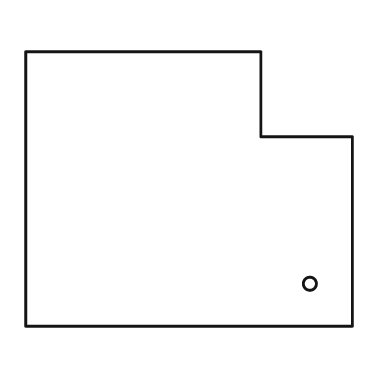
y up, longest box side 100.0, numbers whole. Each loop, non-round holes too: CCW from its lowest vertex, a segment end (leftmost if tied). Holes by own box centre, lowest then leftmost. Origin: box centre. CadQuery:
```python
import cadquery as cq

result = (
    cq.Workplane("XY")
    .moveTo(-50.0, -42.0)
    .lineTo(50.0, -42.0)
    .lineTo(50.0, 16.0)
    .lineTo(22.0, 16.0)
    .lineTo(22.0, 42.0)
    .lineTo(-50.0, 42.0)
    .close()
    .moveTo(37.0, -29.0)
    .circle(2.0)
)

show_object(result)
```